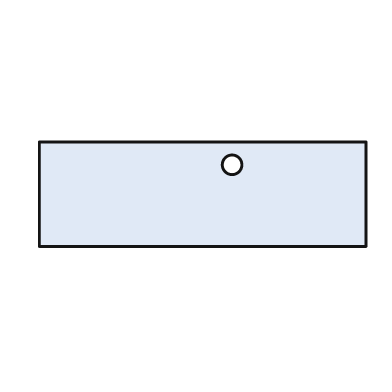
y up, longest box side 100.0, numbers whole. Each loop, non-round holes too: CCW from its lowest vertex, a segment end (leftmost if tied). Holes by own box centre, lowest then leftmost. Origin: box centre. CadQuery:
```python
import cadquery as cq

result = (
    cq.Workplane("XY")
    .moveTo(-50.0, -16.0)
    .lineTo(50.0, -16.0)
    .lineTo(50.0, 16.0)
    .lineTo(-50.0, 16.0)
    .close()
    .moveTo(9.0, 9.0)
    .circle(3.0)
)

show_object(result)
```